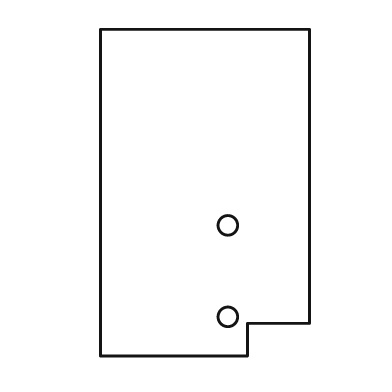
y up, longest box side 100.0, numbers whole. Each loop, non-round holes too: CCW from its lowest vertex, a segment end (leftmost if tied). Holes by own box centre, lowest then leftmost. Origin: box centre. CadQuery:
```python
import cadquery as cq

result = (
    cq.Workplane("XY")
    .moveTo(-32.0, -50.0)
    .lineTo(13.0, -50.0)
    .lineTo(13.0, -40.0)
    .lineTo(32.0, -40.0)
    .lineTo(32.0, 50.0)
    .lineTo(-32.0, 50.0)
    .close()
    .moveTo(7.0, -38.0)
    .circle(3.0)
    .moveTo(7.0, -10.0)
    .circle(3.0)
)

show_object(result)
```